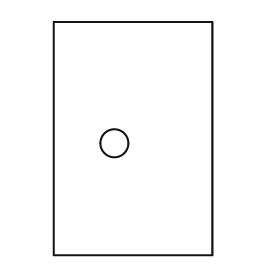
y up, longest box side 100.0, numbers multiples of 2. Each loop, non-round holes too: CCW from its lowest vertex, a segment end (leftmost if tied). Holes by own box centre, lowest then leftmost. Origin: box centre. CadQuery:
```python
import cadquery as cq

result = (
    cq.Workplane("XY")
    .moveTo(-34.0, -50.0)
    .lineTo(34.0, -50.0)
    .lineTo(34.0, 50.0)
    .lineTo(-34.0, 50.0)
    .close()
    .moveTo(-8.0, -2.0)
    .circle(6.0)
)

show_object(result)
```